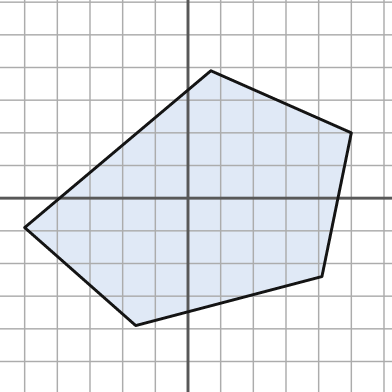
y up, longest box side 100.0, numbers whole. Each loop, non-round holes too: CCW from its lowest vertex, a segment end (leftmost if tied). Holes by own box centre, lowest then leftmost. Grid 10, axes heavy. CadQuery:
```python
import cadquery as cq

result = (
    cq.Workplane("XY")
    .moveTo(-16.0, -39.0)
    .lineTo(41.0, -24.0)
    .lineTo(50.0, 20.0)
    .lineTo(7.0, 39.0)
    .lineTo(-50.0, -9.0)
    .close()
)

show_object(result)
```